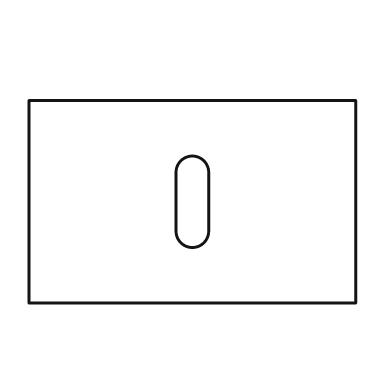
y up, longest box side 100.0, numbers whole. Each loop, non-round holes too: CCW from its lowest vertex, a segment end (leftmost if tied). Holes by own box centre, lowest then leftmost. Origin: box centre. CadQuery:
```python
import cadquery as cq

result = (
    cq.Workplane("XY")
    .moveTo(-50.0, -31.0)
    .lineTo(50.0, -31.0)
    .lineTo(50.0, 31.0)
    .lineTo(-50.0, 31.0)
    .close()
    .moveTo(-5.0, -9.0)
    .threePointArc((0.0, -14.0), (5.0, -9.0))
    .lineTo(5.0, 9.0)
    .threePointArc((0.0, 14.0), (-5.0, 9.0))
    .close()
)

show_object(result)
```